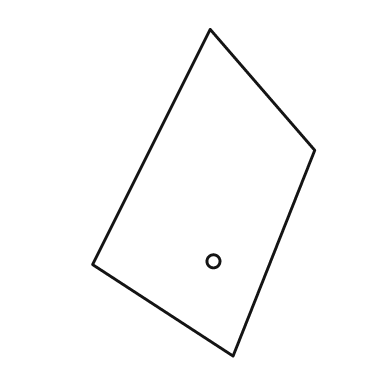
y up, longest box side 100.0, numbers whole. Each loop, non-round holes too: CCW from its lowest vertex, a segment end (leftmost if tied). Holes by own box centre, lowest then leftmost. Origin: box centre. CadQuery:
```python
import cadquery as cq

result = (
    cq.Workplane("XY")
    .moveTo(9.0, -50.0)
    .lineTo(34.0, 13.0)
    .lineTo(2.0, 50.0)
    .lineTo(-34.0, -22.0)
    .close()
    .moveTo(3.0, -21.0)
    .circle(2.0)
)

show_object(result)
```